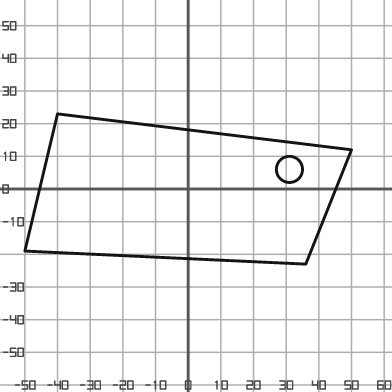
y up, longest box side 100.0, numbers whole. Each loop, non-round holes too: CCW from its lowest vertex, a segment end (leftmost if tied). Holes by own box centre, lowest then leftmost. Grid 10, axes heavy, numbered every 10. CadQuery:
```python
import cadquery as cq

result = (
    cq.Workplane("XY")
    .moveTo(36.0, -23.0)
    .lineTo(50.0, 12.0)
    .lineTo(-40.0, 23.0)
    .lineTo(-50.0, -19.0)
    .close()
    .moveTo(31.0, 6.0)
    .circle(4.0)
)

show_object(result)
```